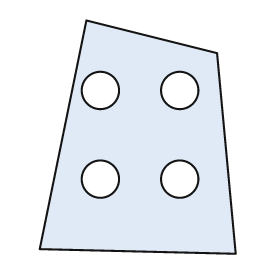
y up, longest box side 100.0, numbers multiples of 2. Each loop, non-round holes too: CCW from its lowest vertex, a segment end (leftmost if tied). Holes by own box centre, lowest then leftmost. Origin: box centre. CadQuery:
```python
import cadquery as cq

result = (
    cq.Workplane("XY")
    .moveTo(42.0, -50.0)
    .lineTo(34.0, 36.0)
    .lineTo(-22.0, 50.0)
    .lineTo(-42.0, -48.0)
    .close()
    .moveTo(-16.0, -18.0)
    .circle(8.0)
    .moveTo(18.0, -18.0)
    .circle(8.0)
    .moveTo(-16.0, 20.0)
    .circle(8.0)
    .moveTo(18.0, 20.0)
    .circle(8.0)
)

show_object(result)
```